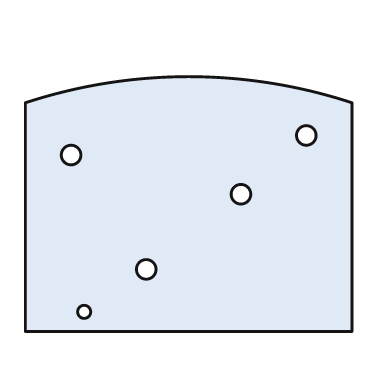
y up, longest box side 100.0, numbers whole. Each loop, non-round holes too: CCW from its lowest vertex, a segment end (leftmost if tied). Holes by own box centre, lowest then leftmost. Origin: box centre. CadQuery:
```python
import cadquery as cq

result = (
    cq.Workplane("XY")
    .moveTo(-50.0, -39.0)
    .lineTo(50.0, -39.0)
    .lineTo(50.0, 31.0)
    .threePointArc((0.0, 39.0), (-50.0, 31.0))
    .close()
    .moveTo(-32.0, -33.0)
    .circle(2.0)
    .moveTo(-13.0, -20.0)
    .circle(3.0)
    .moveTo(16.0, 3.0)
    .circle(3.0)
    .moveTo(-36.0, 15.0)
    .circle(3.0)
    .moveTo(36.0, 21.0)
    .circle(3.0)
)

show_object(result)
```